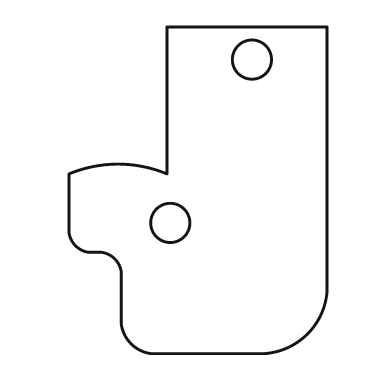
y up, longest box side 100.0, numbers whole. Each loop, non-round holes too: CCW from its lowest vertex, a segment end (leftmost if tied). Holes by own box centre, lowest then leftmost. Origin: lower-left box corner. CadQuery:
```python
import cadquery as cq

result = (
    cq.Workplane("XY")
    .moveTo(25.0, 0.0)
    .lineTo(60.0, 0.0)
    .threePointArc((73.0, 6.0), (79.0, 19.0))
    .lineTo(79.0, 100.0)
    .lineTo(30.0, 100.0)
    .lineTo(30.0, 55.0)
    .threePointArc((15.0, 58.0), (0.0, 55.0))
    .lineTo(0.0, 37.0)
    .threePointArc((2.0, 33.0), (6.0, 31.0))
    .lineTo(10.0, 31.0)
    .threePointArc((14.0, 29.0), (16.0, 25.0))
    .lineTo(16.0, 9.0)
    .threePointArc((19.0, 3.0), (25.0, 0.0))
    .close()
    .moveTo(31.0, 40.0)
    .circle(6.0)
    .moveTo(56.0, 90.0)
    .circle(6.0)
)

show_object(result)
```